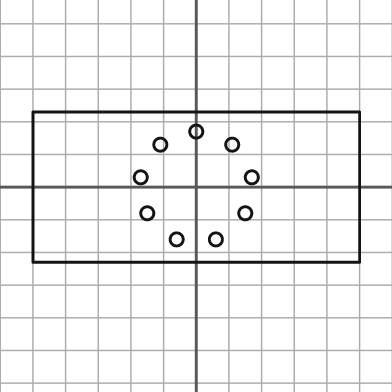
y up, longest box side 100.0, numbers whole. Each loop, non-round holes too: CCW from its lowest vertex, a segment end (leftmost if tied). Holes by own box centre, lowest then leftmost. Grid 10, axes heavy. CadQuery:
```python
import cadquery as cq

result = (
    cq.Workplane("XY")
    .moveTo(-50.0, -23.0)
    .lineTo(50.0, -23.0)
    .lineTo(50.0, 23.0)
    .lineTo(-50.0, 23.0)
    .close()
    .moveTo(-6.0, -16.0)
    .circle(2.0)
    .moveTo(6.0, -16.0)
    .circle(2.0)
    .moveTo(-15.0, -8.0)
    .circle(2.0)
    .moveTo(15.0, -8.0)
    .circle(2.0)
    .moveTo(-17.0, 3.0)
    .circle(2.0)
    .moveTo(17.0, 3.0)
    .circle(2.0)
    .moveTo(-11.0, 13.0)
    .circle(2.0)
    .moveTo(11.0, 13.0)
    .circle(2.0)
    .moveTo(0.0, 17.0)
    .circle(2.0)
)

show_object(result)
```